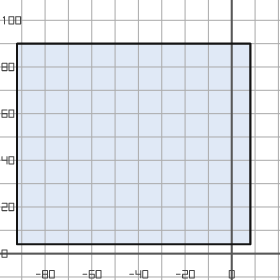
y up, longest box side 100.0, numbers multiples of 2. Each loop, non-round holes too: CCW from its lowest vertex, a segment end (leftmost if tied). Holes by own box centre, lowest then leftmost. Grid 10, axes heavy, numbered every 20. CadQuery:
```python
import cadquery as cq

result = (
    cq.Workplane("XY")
    .moveTo(-92.0, 4.0)
    .lineTo(8.0, 4.0)
    .lineTo(8.0, 90.0)
    .lineTo(-92.0, 90.0)
    .close()
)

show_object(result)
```